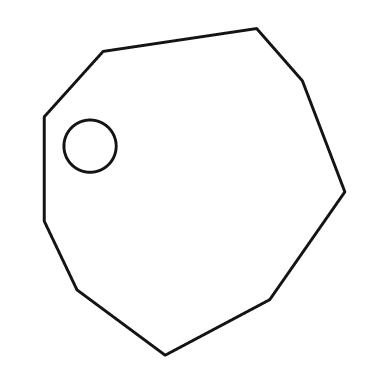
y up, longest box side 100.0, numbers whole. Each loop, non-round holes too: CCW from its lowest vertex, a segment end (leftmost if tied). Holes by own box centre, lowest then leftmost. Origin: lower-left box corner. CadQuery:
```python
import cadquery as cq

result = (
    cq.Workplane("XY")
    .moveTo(37.0, 0.0)
    .lineTo(69.0, 17.0)
    .lineTo(92.0, 50.0)
    .lineTo(79.0, 84.0)
    .lineTo(65.0, 100.0)
    .lineTo(18.0, 93.0)
    .lineTo(0.0, 73.0)
    .lineTo(0.0, 41.0)
    .lineTo(10.0, 20.0)
    .close()
    .moveTo(14.0, 64.0)
    .circle(8.0)
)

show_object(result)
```